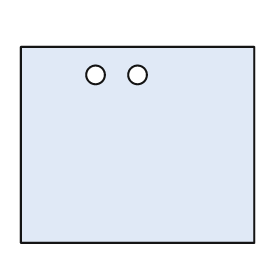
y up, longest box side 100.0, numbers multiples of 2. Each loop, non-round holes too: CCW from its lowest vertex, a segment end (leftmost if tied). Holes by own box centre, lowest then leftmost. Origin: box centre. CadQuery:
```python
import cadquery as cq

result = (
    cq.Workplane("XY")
    .moveTo(-50.0, -42.0)
    .lineTo(50.0, -42.0)
    .lineTo(50.0, 42.0)
    .lineTo(-50.0, 42.0)
    .close()
    .moveTo(-18.0, 30.0)
    .circle(4.0)
    .moveTo(0.0, 30.0)
    .circle(4.0)
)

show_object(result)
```